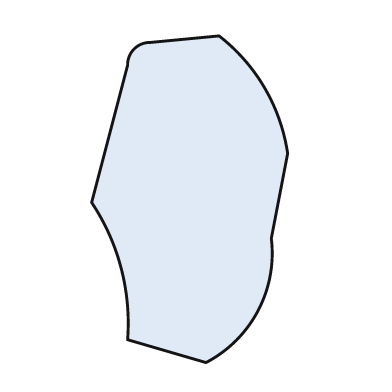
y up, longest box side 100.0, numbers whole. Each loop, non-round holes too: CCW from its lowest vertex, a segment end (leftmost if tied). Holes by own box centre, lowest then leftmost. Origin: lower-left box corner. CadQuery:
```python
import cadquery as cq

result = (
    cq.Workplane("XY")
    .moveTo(35.0, 0.0)
    .threePointArc((51.0, 16.0), (55.0, 38.0))
    .lineTo(60.0, 64.0)
    .threePointArc((53.0, 84.0), (39.0, 100.0))
    .lineTo(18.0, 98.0)
    .threePointArc((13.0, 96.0), (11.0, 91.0))
    .lineTo(0.0, 49.0)
    .threePointArc((9.0, 29.0), (11.0, 7.0))
    .close()
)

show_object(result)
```